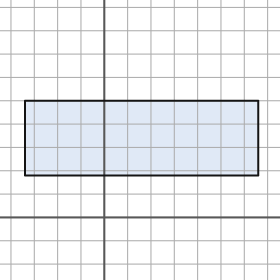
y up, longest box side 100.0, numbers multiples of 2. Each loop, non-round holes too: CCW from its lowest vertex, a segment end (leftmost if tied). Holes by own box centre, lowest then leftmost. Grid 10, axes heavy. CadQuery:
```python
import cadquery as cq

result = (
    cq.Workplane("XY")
    .moveTo(-34.0, 18.0)
    .lineTo(66.0, 18.0)
    .lineTo(66.0, 50.0)
    .lineTo(-34.0, 50.0)
    .close()
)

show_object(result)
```